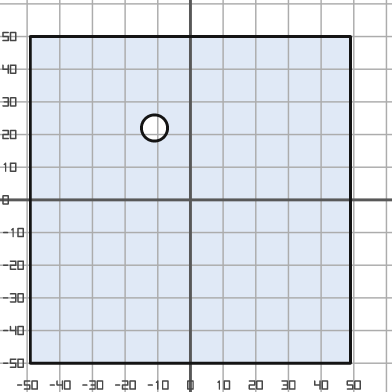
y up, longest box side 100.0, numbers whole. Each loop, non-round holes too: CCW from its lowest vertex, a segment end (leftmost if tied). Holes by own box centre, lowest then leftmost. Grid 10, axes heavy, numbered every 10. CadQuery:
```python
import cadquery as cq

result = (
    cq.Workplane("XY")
    .moveTo(-49.0, -50.0)
    .lineTo(49.0, -50.0)
    .lineTo(49.0, 50.0)
    .lineTo(-49.0, 50.0)
    .close()
    .moveTo(-11.0, 22.0)
    .circle(4.0)
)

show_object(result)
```